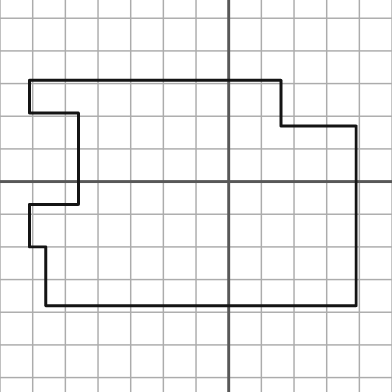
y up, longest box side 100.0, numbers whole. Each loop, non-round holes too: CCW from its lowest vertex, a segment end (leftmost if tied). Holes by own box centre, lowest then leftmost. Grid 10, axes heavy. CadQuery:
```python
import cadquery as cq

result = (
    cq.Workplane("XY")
    .moveTo(-56.0, -38.0)
    .lineTo(39.0, -38.0)
    .lineTo(39.0, 17.0)
    .lineTo(16.0, 17.0)
    .lineTo(16.0, 31.0)
    .lineTo(-61.0, 31.0)
    .lineTo(-61.0, 21.0)
    .lineTo(-46.0, 21.0)
    .lineTo(-46.0, -7.0)
    .lineTo(-61.0, -7.0)
    .lineTo(-61.0, -20.0)
    .lineTo(-56.0, -20.0)
    .close()
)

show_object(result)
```